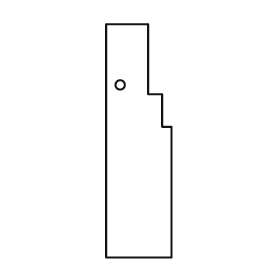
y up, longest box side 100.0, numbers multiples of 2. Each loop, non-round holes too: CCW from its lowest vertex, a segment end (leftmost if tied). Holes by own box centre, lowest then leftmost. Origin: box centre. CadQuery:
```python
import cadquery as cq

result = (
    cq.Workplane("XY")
    .moveTo(-14.0, -50.0)
    .lineTo(14.0, -50.0)
    .lineTo(14.0, 6.0)
    .lineTo(10.0, 6.0)
    .lineTo(10.0, 20.0)
    .lineTo(4.0, 20.0)
    .lineTo(4.0, 50.0)
    .lineTo(-14.0, 50.0)
    .close()
    .moveTo(-8.0, 24.0)
    .circle(2.0)
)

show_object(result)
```